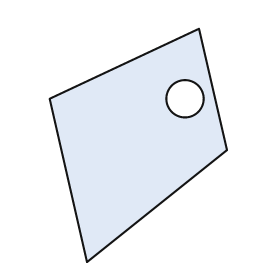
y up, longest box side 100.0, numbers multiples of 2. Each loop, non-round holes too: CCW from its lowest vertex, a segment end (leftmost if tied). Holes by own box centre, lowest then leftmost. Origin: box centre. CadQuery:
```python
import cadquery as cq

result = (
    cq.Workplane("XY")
    .moveTo(-22.0, -50.0)
    .lineTo(38.0, -2.0)
    .lineTo(26.0, 50.0)
    .lineTo(-38.0, 20.0)
    .close()
    .moveTo(20.0, 20.0)
    .circle(8.0)
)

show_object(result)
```